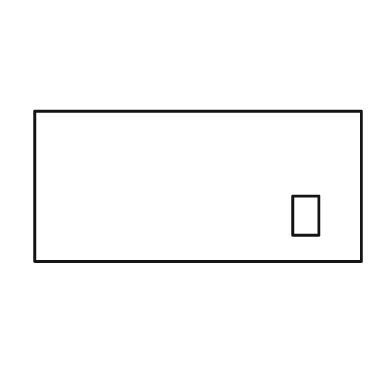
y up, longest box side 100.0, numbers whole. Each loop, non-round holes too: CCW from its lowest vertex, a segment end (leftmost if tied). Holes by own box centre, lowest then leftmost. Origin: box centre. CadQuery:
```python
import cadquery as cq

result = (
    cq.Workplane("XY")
    .moveTo(-50.0, -23.0)
    .lineTo(50.0, -23.0)
    .lineTo(50.0, 23.0)
    .lineTo(-50.0, 23.0)
    .close()
    .moveTo(29.0, -15.0)
    .lineTo(37.0, -15.0)
    .lineTo(37.0, -3.0)
    .lineTo(29.0, -3.0)
    .close()
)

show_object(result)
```